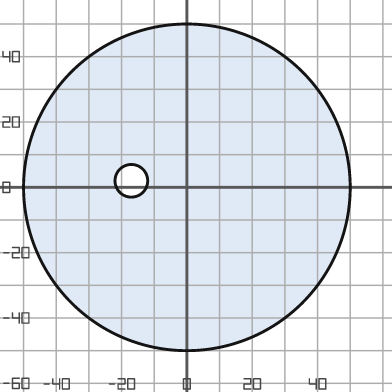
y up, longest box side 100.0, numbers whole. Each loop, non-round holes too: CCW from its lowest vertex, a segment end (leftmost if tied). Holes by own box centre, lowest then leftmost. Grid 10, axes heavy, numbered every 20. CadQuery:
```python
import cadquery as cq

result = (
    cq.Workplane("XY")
    .moveTo(0.0, 0.0)
    .circle(50.0)
    .moveTo(-17.0, 2.0)
    .circle(5.0)
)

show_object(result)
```